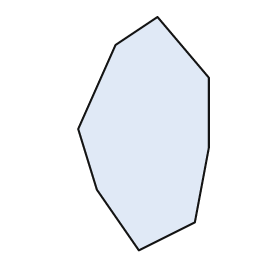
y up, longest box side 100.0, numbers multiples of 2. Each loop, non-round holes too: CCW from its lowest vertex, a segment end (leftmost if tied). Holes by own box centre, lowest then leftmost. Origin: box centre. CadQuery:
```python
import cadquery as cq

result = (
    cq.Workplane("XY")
    .moveTo(-2.0, -50.0)
    .lineTo(22.0, -38.0)
    .lineTo(28.0, -6.0)
    .lineTo(28.0, 24.0)
    .lineTo(6.0, 50.0)
    .lineTo(-12.0, 38.0)
    .lineTo(-28.0, 2.0)
    .lineTo(-20.0, -24.0)
    .close()
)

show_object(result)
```